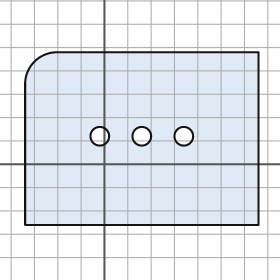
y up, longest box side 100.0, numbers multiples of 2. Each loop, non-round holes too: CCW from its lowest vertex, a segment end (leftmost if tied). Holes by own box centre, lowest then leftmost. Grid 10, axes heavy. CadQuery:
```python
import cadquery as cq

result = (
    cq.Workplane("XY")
    .moveTo(-34.0, -26.0)
    .lineTo(66.0, -26.0)
    .lineTo(66.0, 48.0)
    .lineTo(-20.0, 48.0)
    .threePointArc((-30.0, 44.0), (-34.0, 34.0))
    .close()
    .moveTo(-2.0, 12.0)
    .circle(4.0)
    .moveTo(16.0, 12.0)
    .circle(4.0)
    .moveTo(34.0, 12.0)
    .circle(4.0)
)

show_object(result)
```